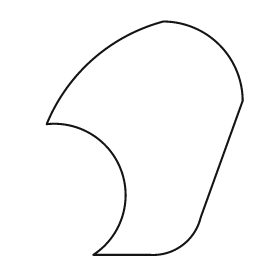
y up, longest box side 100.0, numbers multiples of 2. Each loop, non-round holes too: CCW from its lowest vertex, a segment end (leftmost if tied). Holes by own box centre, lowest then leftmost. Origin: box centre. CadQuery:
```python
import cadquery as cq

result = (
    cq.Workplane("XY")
    .moveTo(-22.0, -50.0)
    .lineTo(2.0, -50.0)
    .threePointArc((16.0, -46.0), (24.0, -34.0))
    .lineTo(42.0, 16.0)
    .threePointArc((32.0, 40.0), (8.0, 50.0))
    .threePointArc((-22.0, 34.0), (-42.0, 6.0))
    .threePointArc((-10.0, -14.0), (-22.0, -50.0))
    .close()
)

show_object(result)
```